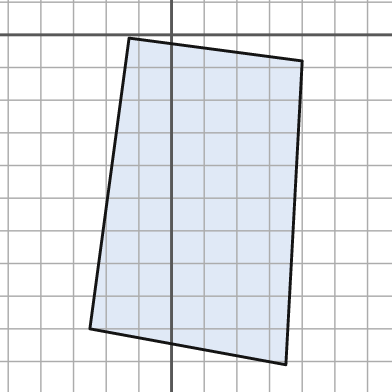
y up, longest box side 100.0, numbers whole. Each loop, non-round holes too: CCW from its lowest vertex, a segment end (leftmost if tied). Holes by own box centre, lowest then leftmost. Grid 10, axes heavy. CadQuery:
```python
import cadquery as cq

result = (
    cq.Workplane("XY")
    .moveTo(35.0, -101.0)
    .lineTo(40.0, -8.0)
    .lineTo(-13.0, -1.0)
    .lineTo(-25.0, -90.0)
    .close()
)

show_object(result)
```